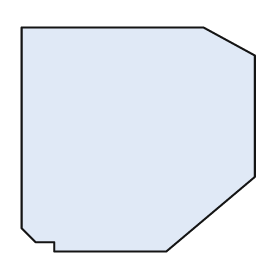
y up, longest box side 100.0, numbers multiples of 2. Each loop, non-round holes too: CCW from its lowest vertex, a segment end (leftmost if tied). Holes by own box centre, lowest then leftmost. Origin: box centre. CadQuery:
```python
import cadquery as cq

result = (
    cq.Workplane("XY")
    .moveTo(-36.0, -48.0)
    .lineTo(12.0, -48.0)
    .lineTo(50.0, -16.0)
    .lineTo(50.0, 36.0)
    .lineTo(28.0, 48.0)
    .lineTo(-50.0, 48.0)
    .lineTo(-50.0, -38.0)
    .lineTo(-44.0, -44.0)
    .lineTo(-36.0, -44.0)
    .close()
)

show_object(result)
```